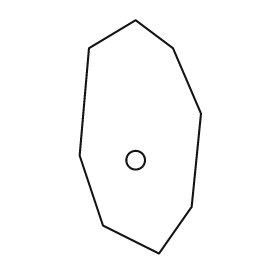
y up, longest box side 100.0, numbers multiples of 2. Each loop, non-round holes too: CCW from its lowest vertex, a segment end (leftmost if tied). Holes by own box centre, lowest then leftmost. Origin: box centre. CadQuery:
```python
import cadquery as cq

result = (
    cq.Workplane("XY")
    .moveTo(8.0, -50.0)
    .lineTo(22.0, -30.0)
    .lineTo(26.0, 10.0)
    .lineTo(14.0, 38.0)
    .lineTo(-2.0, 50.0)
    .lineTo(-22.0, 38.0)
    .lineTo(-26.0, -8.0)
    .lineTo(-16.0, -38.0)
    .close()
    .moveTo(-2.0, -10.0)
    .circle(4.0)
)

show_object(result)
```